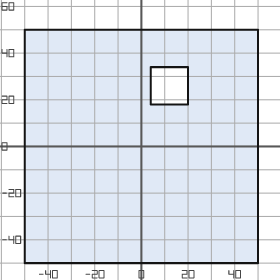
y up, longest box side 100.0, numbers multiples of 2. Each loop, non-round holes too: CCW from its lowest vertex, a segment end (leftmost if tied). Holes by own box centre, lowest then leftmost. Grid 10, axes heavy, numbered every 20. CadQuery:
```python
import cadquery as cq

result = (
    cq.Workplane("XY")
    .moveTo(-50.0, -50.0)
    .lineTo(50.0, -50.0)
    .lineTo(50.0, 50.0)
    .lineTo(-50.0, 50.0)
    .close()
    .moveTo(4.0, 18.0)
    .lineTo(20.0, 18.0)
    .lineTo(20.0, 34.0)
    .lineTo(4.0, 34.0)
    .close()
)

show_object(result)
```